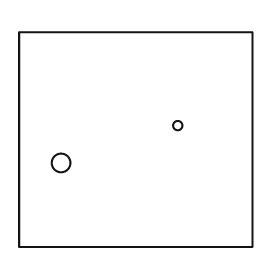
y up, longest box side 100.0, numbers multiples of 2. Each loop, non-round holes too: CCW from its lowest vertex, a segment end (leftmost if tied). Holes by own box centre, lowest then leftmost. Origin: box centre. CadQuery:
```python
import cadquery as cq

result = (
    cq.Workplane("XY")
    .moveTo(-50.0, -46.0)
    .lineTo(50.0, -46.0)
    .lineTo(50.0, 46.0)
    .lineTo(-50.0, 46.0)
    .close()
    .moveTo(-32.0, -10.0)
    .circle(4.0)
    .moveTo(18.0, 6.0)
    .circle(2.0)
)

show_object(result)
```